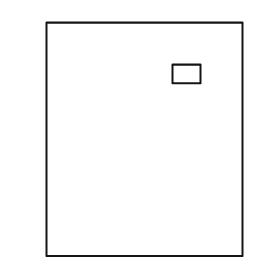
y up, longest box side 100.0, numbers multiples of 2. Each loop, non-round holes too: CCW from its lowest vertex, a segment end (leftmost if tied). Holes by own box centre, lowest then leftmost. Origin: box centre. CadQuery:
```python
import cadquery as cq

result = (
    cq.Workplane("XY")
    .moveTo(-42.0, -50.0)
    .lineTo(42.0, -50.0)
    .lineTo(42.0, 50.0)
    .lineTo(-42.0, 50.0)
    .close()
    .moveTo(12.0, 24.0)
    .lineTo(24.0, 24.0)
    .lineTo(24.0, 32.0)
    .lineTo(12.0, 32.0)
    .close()
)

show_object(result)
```